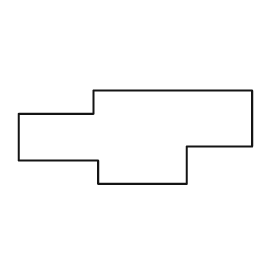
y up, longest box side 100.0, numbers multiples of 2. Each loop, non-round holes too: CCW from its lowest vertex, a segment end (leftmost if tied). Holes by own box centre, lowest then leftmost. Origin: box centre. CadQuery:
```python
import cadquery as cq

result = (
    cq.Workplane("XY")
    .moveTo(-16.0, -20.0)
    .lineTo(22.0, -20.0)
    .lineTo(22.0, -4.0)
    .lineTo(50.0, -4.0)
    .lineTo(50.0, 20.0)
    .lineTo(-18.0, 20.0)
    .lineTo(-18.0, 10.0)
    .lineTo(-50.0, 10.0)
    .lineTo(-50.0, -10.0)
    .lineTo(-16.0, -10.0)
    .close()
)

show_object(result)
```